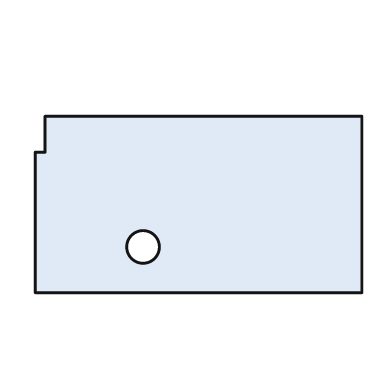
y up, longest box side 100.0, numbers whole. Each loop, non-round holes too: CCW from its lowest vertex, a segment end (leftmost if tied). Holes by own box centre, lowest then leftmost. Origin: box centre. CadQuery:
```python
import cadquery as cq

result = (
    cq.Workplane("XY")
    .moveTo(-50.0, -27.0)
    .lineTo(50.0, -27.0)
    .lineTo(50.0, 27.0)
    .lineTo(-47.0, 27.0)
    .lineTo(-47.0, 16.0)
    .lineTo(-50.0, 16.0)
    .close()
    .moveTo(-17.0, -13.0)
    .circle(5.0)
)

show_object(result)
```